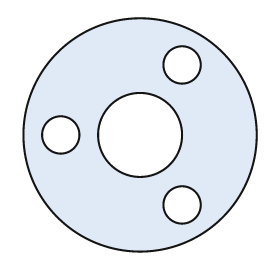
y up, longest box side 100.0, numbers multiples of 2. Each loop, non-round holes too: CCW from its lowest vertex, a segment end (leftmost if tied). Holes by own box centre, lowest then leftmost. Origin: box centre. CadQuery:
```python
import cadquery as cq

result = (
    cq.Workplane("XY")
    .moveTo(0.0, 0.0)
    .circle(50.0)
    .moveTo(18.0, -30.0)
    .circle(8.0)
    .moveTo(-34.0, 0.0)
    .circle(8.0)
    .moveTo(0.0, 0.0)
    .circle(18.0)
    .moveTo(18.0, 30.0)
    .circle(8.0)
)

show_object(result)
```